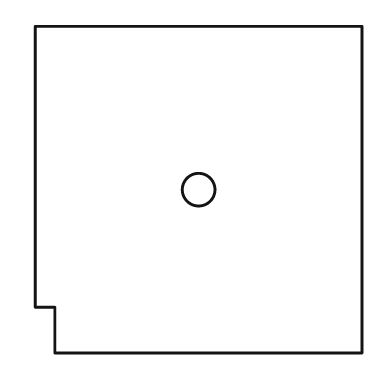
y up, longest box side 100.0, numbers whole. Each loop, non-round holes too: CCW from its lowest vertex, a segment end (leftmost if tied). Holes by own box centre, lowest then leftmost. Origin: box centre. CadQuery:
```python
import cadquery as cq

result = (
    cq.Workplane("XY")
    .moveTo(-44.0, -50.0)
    .lineTo(50.0, -50.0)
    .lineTo(50.0, 50.0)
    .lineTo(-50.0, 50.0)
    .lineTo(-50.0, -36.0)
    .lineTo(-44.0, -36.0)
    .close()
    .moveTo(0.0, 0.0)
    .circle(5.0)
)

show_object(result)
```